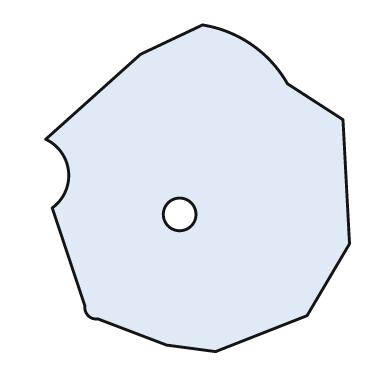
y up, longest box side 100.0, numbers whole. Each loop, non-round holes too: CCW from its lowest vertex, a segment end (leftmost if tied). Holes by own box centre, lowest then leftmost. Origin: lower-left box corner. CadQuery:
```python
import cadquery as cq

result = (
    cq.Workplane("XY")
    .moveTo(52.0, 0.0)
    .lineTo(80.0, 11.0)
    .lineTo(93.0, 33.0)
    .lineTo(91.0, 71.0)
    .lineTo(74.0, 82.0)
    .threePointArc((63.0, 94.0), (48.0, 100.0))
    .lineTo(29.0, 91.0)
    .lineTo(0.0, 65.0)
    .threePointArc((7.0, 55.0), (2.0, 44.0))
    .lineTo(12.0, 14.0)
    .threePointArc((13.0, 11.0), (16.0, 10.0))
    .lineTo(37.0, 2.0)
    .close()
    .moveTo(41.0, 42.0)
    .circle(5.0)
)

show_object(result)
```